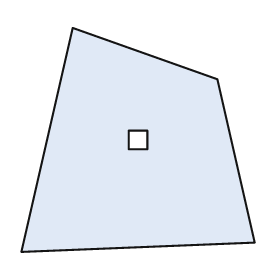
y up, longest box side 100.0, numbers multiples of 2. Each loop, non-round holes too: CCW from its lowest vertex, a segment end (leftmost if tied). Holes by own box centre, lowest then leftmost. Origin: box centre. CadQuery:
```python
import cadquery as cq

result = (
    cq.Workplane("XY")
    .moveTo(-50.0, -48.0)
    .lineTo(50.0, -44.0)
    .lineTo(34.0, 26.0)
    .lineTo(-28.0, 48.0)
    .close()
    .moveTo(-4.0, -4.0)
    .lineTo(4.0, -4.0)
    .lineTo(4.0, 4.0)
    .lineTo(-4.0, 4.0)
    .close()
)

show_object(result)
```